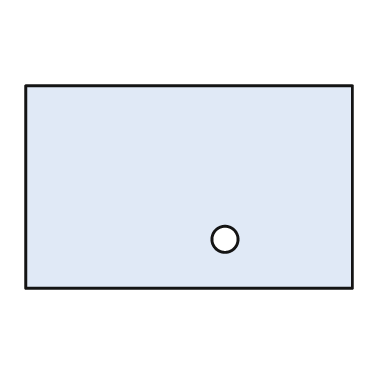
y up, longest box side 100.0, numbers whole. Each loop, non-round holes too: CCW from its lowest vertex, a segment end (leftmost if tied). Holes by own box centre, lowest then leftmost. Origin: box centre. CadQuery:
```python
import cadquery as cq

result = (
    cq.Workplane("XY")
    .moveTo(-50.0, -31.0)
    .lineTo(50.0, -31.0)
    .lineTo(50.0, 31.0)
    .lineTo(-50.0, 31.0)
    .close()
    .moveTo(11.0, -16.0)
    .circle(4.0)
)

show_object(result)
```